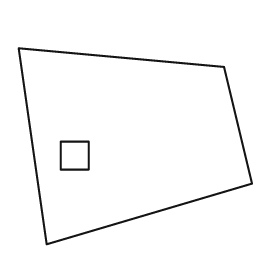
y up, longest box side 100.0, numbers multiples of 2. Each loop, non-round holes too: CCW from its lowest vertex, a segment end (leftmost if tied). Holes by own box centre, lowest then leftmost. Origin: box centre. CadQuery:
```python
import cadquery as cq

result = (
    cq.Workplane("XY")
    .moveTo(-38.0, -42.0)
    .lineTo(50.0, -16.0)
    .lineTo(38.0, 34.0)
    .lineTo(-50.0, 42.0)
    .close()
    .moveTo(-32.0, -10.0)
    .lineTo(-20.0, -10.0)
    .lineTo(-20.0, 2.0)
    .lineTo(-32.0, 2.0)
    .close()
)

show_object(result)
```